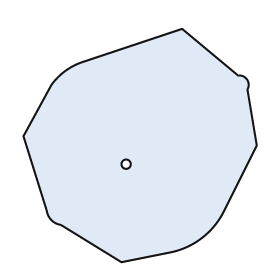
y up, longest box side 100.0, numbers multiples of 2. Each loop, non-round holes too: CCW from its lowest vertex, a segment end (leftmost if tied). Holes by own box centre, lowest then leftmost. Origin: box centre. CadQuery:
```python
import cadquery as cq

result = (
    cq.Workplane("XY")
    .moveTo(-8.0, -50.0)
    .lineTo(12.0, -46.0)
    .threePointArc((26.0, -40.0), (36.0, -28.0))
    .lineTo(50.0, 0.0)
    .lineTo(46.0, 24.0)
    .threePointArc((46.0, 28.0), (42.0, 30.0))
    .lineTo(18.0, 50.0)
    .lineTo(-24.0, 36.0)
    .threePointArc((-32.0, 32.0), (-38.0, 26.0))
    .lineTo(-50.0, 4.0)
    .lineTo(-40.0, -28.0)
    .threePointArc((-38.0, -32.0), (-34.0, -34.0))
    .close()
    .moveTo(-6.0, -8.0)
    .circle(2.0)
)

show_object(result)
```